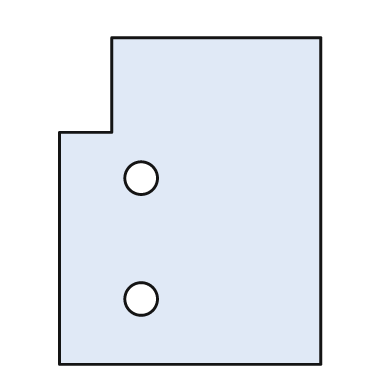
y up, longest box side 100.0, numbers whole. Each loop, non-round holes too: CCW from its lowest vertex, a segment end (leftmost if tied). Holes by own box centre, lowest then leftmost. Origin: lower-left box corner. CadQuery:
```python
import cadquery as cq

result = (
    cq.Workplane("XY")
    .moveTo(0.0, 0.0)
    .lineTo(80.0, 0.0)
    .lineTo(80.0, 100.0)
    .lineTo(16.0, 100.0)
    .lineTo(16.0, 71.0)
    .lineTo(0.0, 71.0)
    .close()
    .moveTo(25.0, 20.0)
    .circle(5.0)
    .moveTo(25.0, 57.0)
    .circle(5.0)
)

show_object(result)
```